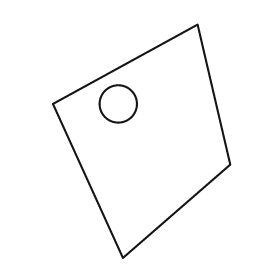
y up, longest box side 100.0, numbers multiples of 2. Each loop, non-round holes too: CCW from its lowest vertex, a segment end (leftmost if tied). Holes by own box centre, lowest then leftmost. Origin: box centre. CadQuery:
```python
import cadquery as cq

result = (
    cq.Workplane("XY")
    .moveTo(-8.0, -50.0)
    .lineTo(38.0, -10.0)
    .lineTo(24.0, 50.0)
    .lineTo(-38.0, 16.0)
    .close()
    .moveTo(-10.0, 16.0)
    .circle(8.0)
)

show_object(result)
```